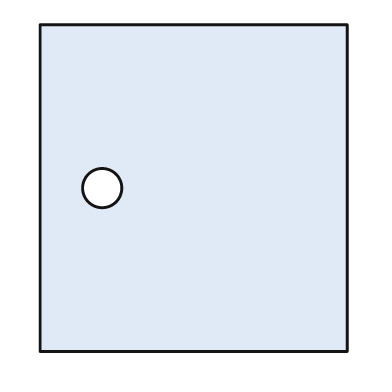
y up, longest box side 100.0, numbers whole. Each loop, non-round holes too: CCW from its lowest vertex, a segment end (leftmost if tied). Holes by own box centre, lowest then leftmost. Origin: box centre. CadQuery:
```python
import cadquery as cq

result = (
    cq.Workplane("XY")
    .moveTo(-47.0, -50.0)
    .lineTo(47.0, -50.0)
    .lineTo(47.0, 50.0)
    .lineTo(-47.0, 50.0)
    .close()
    .moveTo(-28.0, 0.0)
    .circle(6.0)
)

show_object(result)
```